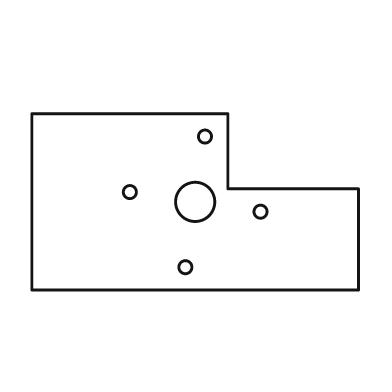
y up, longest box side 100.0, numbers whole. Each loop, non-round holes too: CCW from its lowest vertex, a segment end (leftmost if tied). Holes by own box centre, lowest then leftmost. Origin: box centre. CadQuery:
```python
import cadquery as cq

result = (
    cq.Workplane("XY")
    .moveTo(-50.0, -27.0)
    .lineTo(50.0, -27.0)
    .lineTo(50.0, 4.0)
    .lineTo(10.0, 4.0)
    .lineTo(10.0, 27.0)
    .lineTo(-50.0, 27.0)
    .close()
    .moveTo(-3.0, -20.0)
    .circle(2.0)
    .moveTo(20.0, -3.0)
    .circle(2.0)
    .moveTo(0.0, 0.0)
    .circle(6.0)
    .moveTo(-20.0, 3.0)
    .circle(2.0)
    .moveTo(3.0, 20.0)
    .circle(2.0)
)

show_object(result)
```